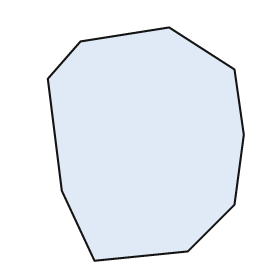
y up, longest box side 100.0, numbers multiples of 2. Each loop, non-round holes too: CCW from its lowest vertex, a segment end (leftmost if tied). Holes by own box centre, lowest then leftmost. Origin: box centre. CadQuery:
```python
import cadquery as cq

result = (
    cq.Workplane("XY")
    .moveTo(-22.0, -50.0)
    .lineTo(18.0, -46.0)
    .lineTo(38.0, -26.0)
    .lineTo(42.0, 4.0)
    .lineTo(38.0, 32.0)
    .lineTo(10.0, 50.0)
    .lineTo(-28.0, 44.0)
    .lineTo(-42.0, 28.0)
    .lineTo(-36.0, -20.0)
    .close()
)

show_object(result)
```